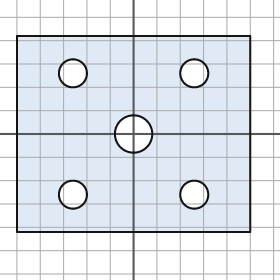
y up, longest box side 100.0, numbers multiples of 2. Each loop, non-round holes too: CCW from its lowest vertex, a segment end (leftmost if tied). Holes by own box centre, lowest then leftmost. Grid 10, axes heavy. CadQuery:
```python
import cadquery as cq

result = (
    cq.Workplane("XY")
    .moveTo(-50.0, -42.0)
    .lineTo(50.0, -42.0)
    .lineTo(50.0, 42.0)
    .lineTo(-50.0, 42.0)
    .close()
    .moveTo(-26.0, -26.0)
    .circle(6.0)
    .moveTo(26.0, -26.0)
    .circle(6.0)
    .moveTo(0.0, 0.0)
    .circle(8.0)
    .moveTo(-26.0, 26.0)
    .circle(6.0)
    .moveTo(26.0, 26.0)
    .circle(6.0)
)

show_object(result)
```